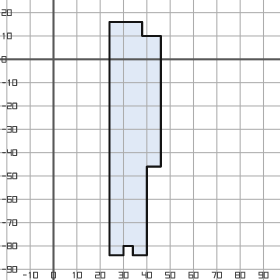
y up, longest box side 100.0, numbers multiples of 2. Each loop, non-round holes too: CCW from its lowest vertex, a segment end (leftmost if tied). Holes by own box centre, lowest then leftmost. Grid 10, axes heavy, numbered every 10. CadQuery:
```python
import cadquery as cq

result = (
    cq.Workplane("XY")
    .moveTo(24.0, -84.0)
    .lineTo(30.0, -84.0)
    .lineTo(30.0, -80.0)
    .lineTo(34.0, -80.0)
    .lineTo(34.0, -84.0)
    .lineTo(40.0, -84.0)
    .lineTo(40.0, -46.0)
    .lineTo(46.0, -46.0)
    .lineTo(46.0, 10.0)
    .lineTo(38.0, 10.0)
    .lineTo(38.0, 16.0)
    .lineTo(24.0, 16.0)
    .close()
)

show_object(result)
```